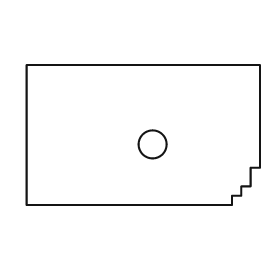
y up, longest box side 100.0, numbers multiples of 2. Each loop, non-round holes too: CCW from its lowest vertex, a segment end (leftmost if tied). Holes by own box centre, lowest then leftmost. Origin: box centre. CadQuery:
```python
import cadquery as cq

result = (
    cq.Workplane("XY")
    .moveTo(-50.0, -30.0)
    .lineTo(38.0, -30.0)
    .lineTo(38.0, -26.0)
    .lineTo(42.0, -26.0)
    .lineTo(42.0, -22.0)
    .lineTo(46.0, -22.0)
    .lineTo(46.0, -14.0)
    .lineTo(50.0, -14.0)
    .lineTo(50.0, 30.0)
    .lineTo(-50.0, 30.0)
    .close()
    .moveTo(4.0, -4.0)
    .circle(6.0)
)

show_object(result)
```